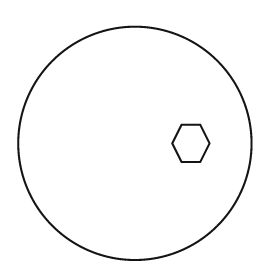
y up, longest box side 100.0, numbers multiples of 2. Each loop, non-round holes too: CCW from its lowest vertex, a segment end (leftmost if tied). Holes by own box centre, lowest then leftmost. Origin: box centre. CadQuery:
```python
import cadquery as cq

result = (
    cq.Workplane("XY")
    .moveTo(0.0, 0.0)
    .circle(50.0)
    .moveTo(20.0, -8.0)
    .lineTo(28.0, -8.0)
    .lineTo(32.0, 0.0)
    .lineTo(28.0, 8.0)
    .lineTo(20.0, 8.0)
    .lineTo(16.0, 0.0)
    .close()
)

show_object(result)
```